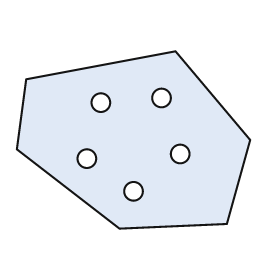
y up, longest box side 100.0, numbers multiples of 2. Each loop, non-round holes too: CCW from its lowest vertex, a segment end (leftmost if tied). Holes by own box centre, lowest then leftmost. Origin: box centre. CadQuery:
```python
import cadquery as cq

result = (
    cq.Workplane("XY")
    .moveTo(-6.0, -38.0)
    .lineTo(40.0, -36.0)
    .lineTo(50.0, 0.0)
    .lineTo(18.0, 38.0)
    .lineTo(-46.0, 26.0)
    .lineTo(-50.0, -4.0)
    .close()
    .moveTo(0.0, -22.0)
    .circle(4.0)
    .moveTo(-20.0, -8.0)
    .circle(4.0)
    .moveTo(20.0, -6.0)
    .circle(4.0)
    .moveTo(-14.0, 16.0)
    .circle(4.0)
    .moveTo(12.0, 18.0)
    .circle(4.0)
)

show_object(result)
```